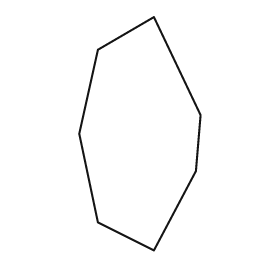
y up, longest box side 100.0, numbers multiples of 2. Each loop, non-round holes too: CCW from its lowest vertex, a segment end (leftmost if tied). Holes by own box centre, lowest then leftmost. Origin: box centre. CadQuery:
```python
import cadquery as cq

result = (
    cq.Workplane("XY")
    .moveTo(6.0, -50.0)
    .lineTo(24.0, -16.0)
    .lineTo(26.0, 8.0)
    .lineTo(6.0, 50.0)
    .lineTo(-18.0, 36.0)
    .lineTo(-26.0, 0.0)
    .lineTo(-18.0, -38.0)
    .close()
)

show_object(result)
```